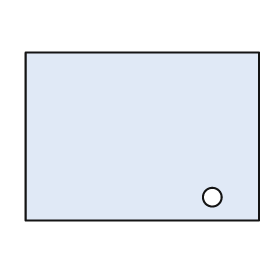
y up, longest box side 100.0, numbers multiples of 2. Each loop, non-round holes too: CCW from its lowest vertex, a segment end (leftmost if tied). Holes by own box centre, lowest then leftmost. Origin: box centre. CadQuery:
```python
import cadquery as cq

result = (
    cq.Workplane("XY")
    .moveTo(-50.0, -36.0)
    .lineTo(50.0, -36.0)
    .lineTo(50.0, 36.0)
    .lineTo(-50.0, 36.0)
    .close()
    .moveTo(30.0, -26.0)
    .circle(4.0)
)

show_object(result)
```